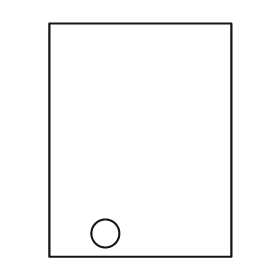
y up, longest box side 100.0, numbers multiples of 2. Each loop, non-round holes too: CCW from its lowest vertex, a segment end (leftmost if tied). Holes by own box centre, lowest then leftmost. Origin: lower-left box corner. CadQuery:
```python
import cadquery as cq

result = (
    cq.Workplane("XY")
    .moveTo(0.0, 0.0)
    .lineTo(78.0, 0.0)
    .lineTo(78.0, 100.0)
    .lineTo(0.0, 100.0)
    .close()
    .moveTo(24.0, 10.0)
    .circle(6.0)
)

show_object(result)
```